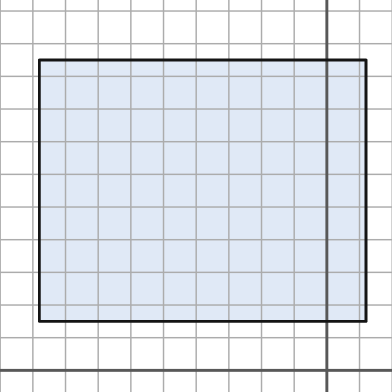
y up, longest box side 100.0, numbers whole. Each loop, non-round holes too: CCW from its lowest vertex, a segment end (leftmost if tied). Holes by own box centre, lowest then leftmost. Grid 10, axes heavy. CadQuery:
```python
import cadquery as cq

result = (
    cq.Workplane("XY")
    .moveTo(-88.0, 15.0)
    .lineTo(12.0, 15.0)
    .lineTo(12.0, 95.0)
    .lineTo(-88.0, 95.0)
    .close()
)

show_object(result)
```